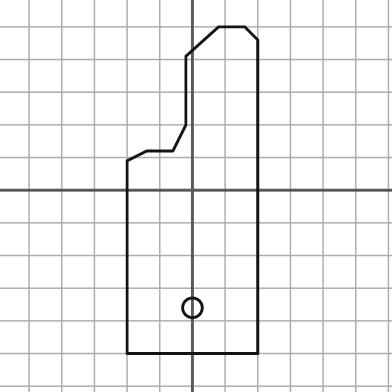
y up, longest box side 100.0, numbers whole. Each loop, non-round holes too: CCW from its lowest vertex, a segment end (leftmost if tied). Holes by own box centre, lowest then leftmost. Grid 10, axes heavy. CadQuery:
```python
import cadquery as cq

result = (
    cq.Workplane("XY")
    .moveTo(-20.0, -50.0)
    .lineTo(20.0, -50.0)
    .lineTo(20.0, 46.0)
    .lineTo(16.0, 50.0)
    .lineTo(8.0, 50.0)
    .lineTo(-2.0, 41.0)
    .lineTo(-2.0, 20.0)
    .lineTo(-6.0, 12.0)
    .lineTo(-14.0, 12.0)
    .lineTo(-20.0, 9.0)
    .close()
    .moveTo(0.0, -36.0)
    .circle(3.0)
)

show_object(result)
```